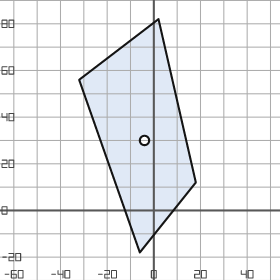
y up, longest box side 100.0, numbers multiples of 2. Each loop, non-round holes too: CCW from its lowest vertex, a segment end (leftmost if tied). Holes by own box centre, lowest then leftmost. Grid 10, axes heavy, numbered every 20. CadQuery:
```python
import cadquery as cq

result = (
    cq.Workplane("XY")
    .moveTo(-6.0, -18.0)
    .lineTo(18.0, 12.0)
    .lineTo(2.0, 82.0)
    .lineTo(-32.0, 56.0)
    .close()
    .moveTo(-4.0, 30.0)
    .circle(2.0)
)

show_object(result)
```